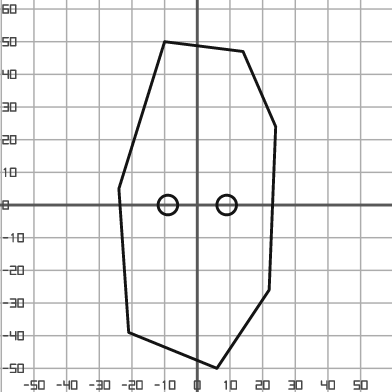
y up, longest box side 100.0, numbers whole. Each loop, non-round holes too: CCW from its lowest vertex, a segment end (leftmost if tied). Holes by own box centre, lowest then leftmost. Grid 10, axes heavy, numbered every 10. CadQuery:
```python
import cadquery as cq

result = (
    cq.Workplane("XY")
    .moveTo(6.0, -50.0)
    .lineTo(22.0, -26.0)
    .lineTo(24.0, 24.0)
    .lineTo(14.0, 47.0)
    .lineTo(-10.0, 50.0)
    .lineTo(-24.0, 5.0)
    .lineTo(-21.0, -39.0)
    .close()
    .moveTo(-9.0, 0.0)
    .circle(3.0)
    .moveTo(9.0, 0.0)
    .circle(3.0)
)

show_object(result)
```